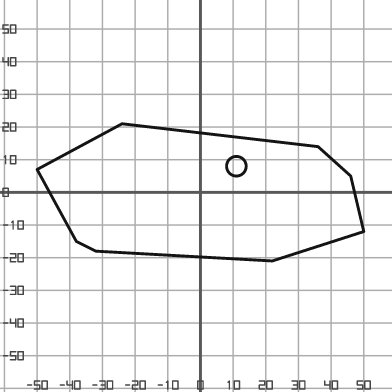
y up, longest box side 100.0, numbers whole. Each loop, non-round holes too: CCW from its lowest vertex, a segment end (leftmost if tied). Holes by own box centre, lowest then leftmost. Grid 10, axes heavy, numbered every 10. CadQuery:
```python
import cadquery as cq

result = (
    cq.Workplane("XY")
    .moveTo(22.0, -21.0)
    .lineTo(50.0, -12.0)
    .lineTo(46.0, 5.0)
    .lineTo(36.0, 14.0)
    .lineTo(-24.0, 21.0)
    .lineTo(-50.0, 7.0)
    .lineTo(-38.0, -15.0)
    .lineTo(-32.0, -18.0)
    .close()
    .moveTo(11.0, 8.0)
    .circle(3.0)
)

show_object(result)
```